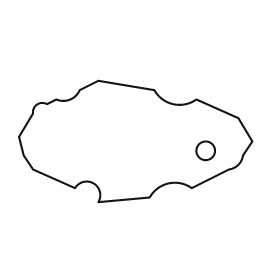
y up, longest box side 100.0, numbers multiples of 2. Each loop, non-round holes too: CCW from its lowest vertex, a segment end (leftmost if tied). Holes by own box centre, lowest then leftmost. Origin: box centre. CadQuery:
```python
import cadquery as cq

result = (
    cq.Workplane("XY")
    .moveTo(-16.0, -26.0)
    .lineTo(6.0, -24.0)
    .threePointArc((14.0, -18.0), (24.0, -20.0))
    .lineTo(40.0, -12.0)
    .threePointArc((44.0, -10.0), (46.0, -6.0))
    .lineTo(50.0, 0.0)
    .lineTo(44.0, 10.0)
    .lineTo(26.0, 18.0)
    .threePointArc((16.0, 16.0), (8.0, 22.0))
    .lineTo(-16.0, 26.0)
    .lineTo(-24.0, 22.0)
    .threePointArc((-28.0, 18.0), (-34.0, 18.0))
    .lineTo(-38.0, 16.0)
    .threePointArc((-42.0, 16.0), (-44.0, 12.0))
    .lineTo(-50.0, 2.0)
    .lineTo(-48.0, -6.0)
    .lineTo(-44.0, -12.0)
    .lineTo(-26.0, -20.0)
    .threePointArc((-18.0, -18.0), (-16.0, -26.0))
    .close()
    .moveTo(30.0, -4.0)
    .circle(4.0)
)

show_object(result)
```